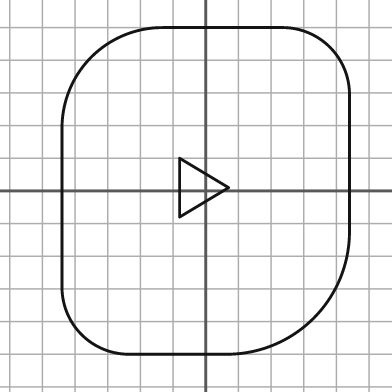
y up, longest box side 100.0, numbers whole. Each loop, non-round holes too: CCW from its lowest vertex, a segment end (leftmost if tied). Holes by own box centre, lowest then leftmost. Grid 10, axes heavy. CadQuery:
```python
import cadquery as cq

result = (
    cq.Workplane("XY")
    .moveTo(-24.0, -50.0)
    .lineTo(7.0, -50.0)
    .threePointArc((33.0, -39.0), (44.0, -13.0))
    .lineTo(44.0, 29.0)
    .threePointArc((38.0, 44.0), (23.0, 50.0))
    .lineTo(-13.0, 50.0)
    .threePointArc((-35.0, 41.0), (-44.0, 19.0))
    .lineTo(-44.0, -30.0)
    .threePointArc((-38.0, -44.0), (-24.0, -50.0))
    .close()
    .moveTo(-8.0, -8.0)
    .lineTo(7.0, 1.0)
    .lineTo(-8.0, 10.0)
    .close()
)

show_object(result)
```